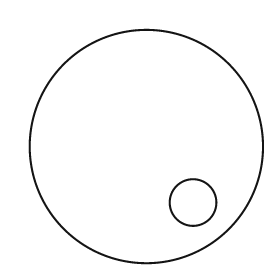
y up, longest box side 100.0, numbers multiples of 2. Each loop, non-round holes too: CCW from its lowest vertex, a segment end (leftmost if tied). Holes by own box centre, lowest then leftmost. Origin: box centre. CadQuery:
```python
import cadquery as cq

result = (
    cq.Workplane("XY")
    .moveTo(0.0, 0.0)
    .circle(50.0)
    .moveTo(20.0, -24.0)
    .circle(10.0)
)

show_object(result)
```